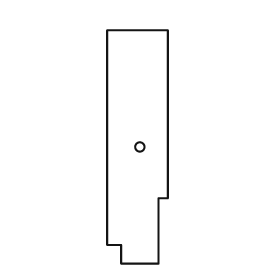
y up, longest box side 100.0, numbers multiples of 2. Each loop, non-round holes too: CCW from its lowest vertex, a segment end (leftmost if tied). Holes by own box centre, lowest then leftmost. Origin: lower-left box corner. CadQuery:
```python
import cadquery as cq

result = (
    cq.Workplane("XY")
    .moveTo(6.0, 0.0)
    .lineTo(22.0, 0.0)
    .lineTo(22.0, 28.0)
    .lineTo(26.0, 28.0)
    .lineTo(26.0, 100.0)
    .lineTo(0.0, 100.0)
    .lineTo(0.0, 8.0)
    .lineTo(6.0, 8.0)
    .close()
    .moveTo(14.0, 50.0)
    .circle(2.0)
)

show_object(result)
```